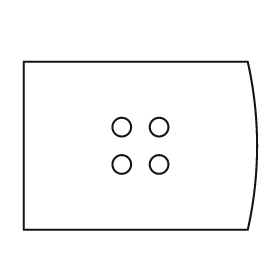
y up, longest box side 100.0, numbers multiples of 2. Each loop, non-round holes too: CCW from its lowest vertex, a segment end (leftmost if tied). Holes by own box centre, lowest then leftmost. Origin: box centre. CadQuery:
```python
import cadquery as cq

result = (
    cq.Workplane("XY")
    .moveTo(-50.0, -36.0)
    .lineTo(46.0, -36.0)
    .threePointArc((50.0, 0.0), (46.0, 36.0))
    .lineTo(-50.0, 36.0)
    .close()
    .moveTo(-8.0, -8.0)
    .circle(4.0)
    .moveTo(8.0, -8.0)
    .circle(4.0)
    .moveTo(-8.0, 8.0)
    .circle(4.0)
    .moveTo(8.0, 8.0)
    .circle(4.0)
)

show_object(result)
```